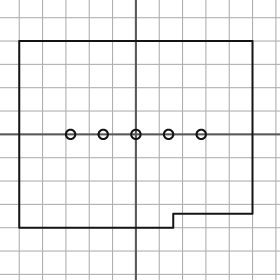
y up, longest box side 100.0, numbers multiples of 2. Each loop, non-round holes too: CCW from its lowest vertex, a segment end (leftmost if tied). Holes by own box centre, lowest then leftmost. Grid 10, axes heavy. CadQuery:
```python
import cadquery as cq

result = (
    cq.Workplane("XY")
    .moveTo(-50.0, -40.0)
    .lineTo(16.0, -40.0)
    .lineTo(16.0, -34.0)
    .lineTo(50.0, -34.0)
    .lineTo(50.0, 40.0)
    .lineTo(-50.0, 40.0)
    .close()
    .moveTo(-28.0, 0.0)
    .circle(2.0)
    .moveTo(-14.0, 0.0)
    .circle(2.0)
    .moveTo(0.0, 0.0)
    .circle(2.0)
    .moveTo(14.0, 0.0)
    .circle(2.0)
    .moveTo(28.0, 0.0)
    .circle(2.0)
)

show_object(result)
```